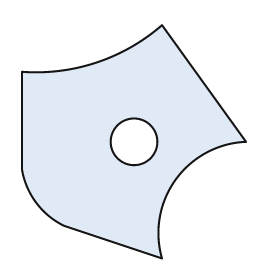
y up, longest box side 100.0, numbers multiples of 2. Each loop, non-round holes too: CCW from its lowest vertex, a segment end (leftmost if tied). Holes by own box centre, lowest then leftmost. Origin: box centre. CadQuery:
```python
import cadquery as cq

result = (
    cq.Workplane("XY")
    .moveTo(12.0, -50.0)
    .threePointArc((18.0, -16.0), (48.0, 0.0))
    .lineTo(12.0, 50.0)
    .threePointArc((-16.0, 34.0), (-48.0, 30.0))
    .lineTo(-48.0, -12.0)
    .threePointArc((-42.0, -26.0), (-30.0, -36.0))
    .close()
    .moveTo(0.0, 0.0)
    .circle(10.0)
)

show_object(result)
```